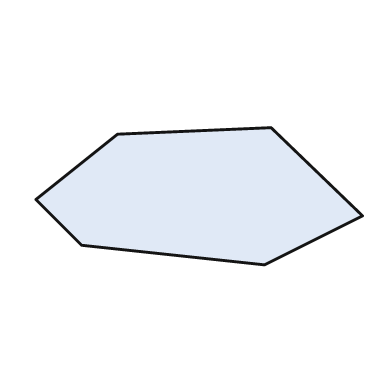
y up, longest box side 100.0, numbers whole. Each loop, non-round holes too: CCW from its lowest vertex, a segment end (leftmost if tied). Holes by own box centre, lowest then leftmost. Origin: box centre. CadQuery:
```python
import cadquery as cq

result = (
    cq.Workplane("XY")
    .moveTo(20.0, -21.0)
    .lineTo(50.0, -6.0)
    .lineTo(22.0, 21.0)
    .lineTo(-25.0, 19.0)
    .lineTo(-50.0, -1.0)
    .lineTo(-36.0, -15.0)
    .close()
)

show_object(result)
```